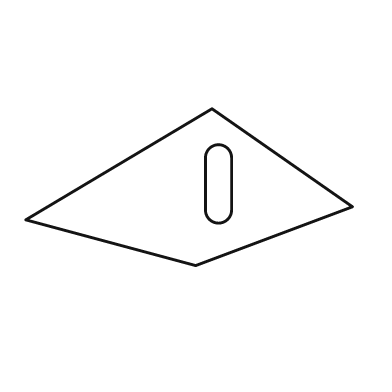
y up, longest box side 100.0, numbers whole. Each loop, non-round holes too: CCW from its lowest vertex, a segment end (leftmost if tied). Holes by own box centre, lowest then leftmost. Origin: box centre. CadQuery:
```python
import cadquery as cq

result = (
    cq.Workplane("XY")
    .moveTo(2.0, -24.0)
    .lineTo(50.0, -6.0)
    .lineTo(7.0, 24.0)
    .lineTo(-50.0, -10.0)
    .close()
    .moveTo(5.0, -7.0)
    .threePointArc((9.0, -11.0), (13.0, -7.0))
    .lineTo(13.0, 9.0)
    .threePointArc((9.0, 13.0), (5.0, 9.0))
    .close()
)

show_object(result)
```